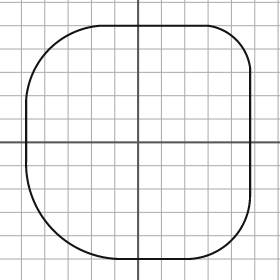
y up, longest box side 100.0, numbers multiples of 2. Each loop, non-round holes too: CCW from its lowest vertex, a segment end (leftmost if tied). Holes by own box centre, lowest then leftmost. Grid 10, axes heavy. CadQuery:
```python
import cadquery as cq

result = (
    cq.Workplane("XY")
    .moveTo(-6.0, -50.0)
    .lineTo(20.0, -50.0)
    .threePointArc((40.0, -42.0), (48.0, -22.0))
    .lineTo(48.0, 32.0)
    .threePointArc((42.0, 44.0), (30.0, 50.0))
    .lineTo(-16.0, 50.0)
    .threePointArc((-38.0, 40.0), (-48.0, 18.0))
    .lineTo(-48.0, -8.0)
    .threePointArc((-36.0, -38.0), (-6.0, -50.0))
    .close()
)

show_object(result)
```